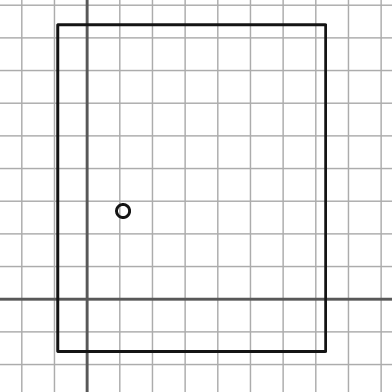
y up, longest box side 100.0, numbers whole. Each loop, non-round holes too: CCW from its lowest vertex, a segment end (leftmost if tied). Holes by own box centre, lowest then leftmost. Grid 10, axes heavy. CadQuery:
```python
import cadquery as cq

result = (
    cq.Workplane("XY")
    .moveTo(-9.0, -16.0)
    .lineTo(73.0, -16.0)
    .lineTo(73.0, 84.0)
    .lineTo(-9.0, 84.0)
    .close()
    .moveTo(11.0, 27.0)
    .circle(2.0)
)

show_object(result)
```